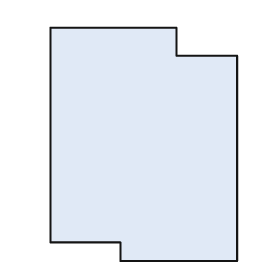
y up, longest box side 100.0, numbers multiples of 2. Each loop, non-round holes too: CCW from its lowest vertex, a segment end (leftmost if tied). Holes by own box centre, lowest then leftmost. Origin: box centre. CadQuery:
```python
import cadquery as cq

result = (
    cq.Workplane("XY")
    .moveTo(-10.0, -50.0)
    .lineTo(40.0, -50.0)
    .lineTo(40.0, 38.0)
    .lineTo(14.0, 38.0)
    .lineTo(14.0, 50.0)
    .lineTo(-40.0, 50.0)
    .lineTo(-40.0, -42.0)
    .lineTo(-10.0, -42.0)
    .close()
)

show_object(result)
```